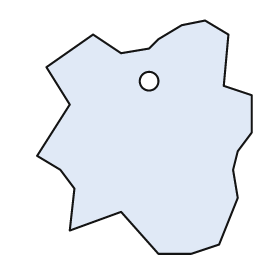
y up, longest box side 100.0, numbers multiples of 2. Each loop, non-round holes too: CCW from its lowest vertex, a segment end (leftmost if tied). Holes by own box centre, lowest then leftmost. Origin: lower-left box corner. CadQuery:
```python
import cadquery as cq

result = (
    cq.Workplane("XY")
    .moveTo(52.0, 0.0)
    .lineTo(66.0, 0.0)
    .lineTo(78.0, 4.0)
    .lineTo(86.0, 24.0)
    .lineTo(84.0, 36.0)
    .lineTo(86.0, 44.0)
    .lineTo(92.0, 52.0)
    .lineTo(92.0, 68.0)
    .lineTo(80.0, 72.0)
    .lineTo(82.0, 94.0)
    .lineTo(72.0, 100.0)
    .lineTo(62.0, 98.0)
    .lineTo(52.0, 92.0)
    .lineTo(48.0, 88.0)
    .lineTo(36.0, 86.0)
    .lineTo(24.0, 94.0)
    .lineTo(4.0, 80.0)
    .lineTo(14.0, 64.0)
    .lineTo(0.0, 42.0)
    .lineTo(10.0, 36.0)
    .lineTo(16.0, 28.0)
    .lineTo(14.0, 10.0)
    .lineTo(36.0, 18.0)
    .close()
    .moveTo(48.0, 74.0)
    .circle(4.0)
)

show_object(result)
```